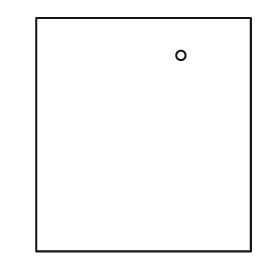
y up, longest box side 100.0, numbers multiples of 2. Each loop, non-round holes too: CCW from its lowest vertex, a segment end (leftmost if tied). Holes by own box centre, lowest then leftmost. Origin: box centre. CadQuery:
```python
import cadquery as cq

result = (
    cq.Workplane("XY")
    .moveTo(-46.0, -50.0)
    .lineTo(46.0, -50.0)
    .lineTo(46.0, 50.0)
    .lineTo(-46.0, 50.0)
    .close()
    .moveTo(16.0, 34.0)
    .circle(2.0)
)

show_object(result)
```